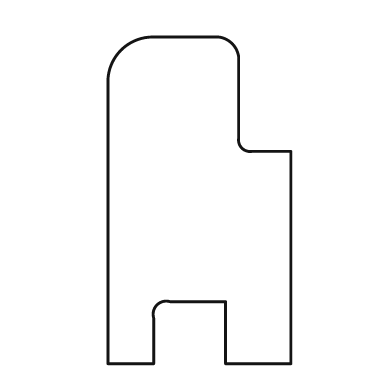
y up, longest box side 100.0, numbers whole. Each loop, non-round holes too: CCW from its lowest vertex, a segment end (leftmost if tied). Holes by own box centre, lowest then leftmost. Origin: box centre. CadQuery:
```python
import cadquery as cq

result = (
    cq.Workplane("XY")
    .moveTo(-28.0, -50.0)
    .lineTo(-14.0, -50.0)
    .lineTo(-14.0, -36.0)
    .threePointArc((-13.0, -32.0), (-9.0, -31.0))
    .lineTo(8.0, -31.0)
    .lineTo(8.0, -50.0)
    .lineTo(28.0, -50.0)
    .lineTo(28.0, 15.0)
    .lineTo(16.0, 15.0)
    .threePointArc((13.0, 16.0), (12.0, 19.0))
    .lineTo(12.0, 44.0)
    .threePointArc((10.0, 48.0), (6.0, 50.0))
    .lineTo(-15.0, 50.0)
    .threePointArc((-24.0, 46.0), (-28.0, 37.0))
    .close()
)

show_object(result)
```